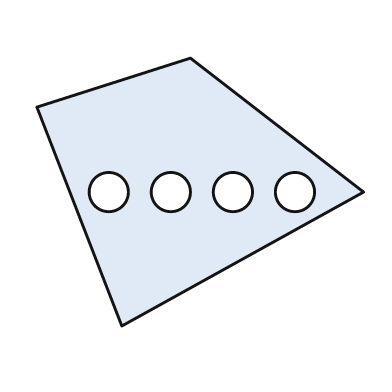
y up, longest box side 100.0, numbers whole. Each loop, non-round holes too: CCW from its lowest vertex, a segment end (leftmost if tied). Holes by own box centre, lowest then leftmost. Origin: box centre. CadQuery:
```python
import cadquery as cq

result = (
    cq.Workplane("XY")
    .moveTo(-24.0, -41.0)
    .lineTo(50.0, 0.0)
    .lineTo(-3.0, 41.0)
    .lineTo(-50.0, 26.0)
    .close()
    .moveTo(-28.0, 0.0)
    .circle(6.0)
    .moveTo(-9.0, 0.0)
    .circle(6.0)
    .moveTo(10.0, 0.0)
    .circle(6.0)
    .moveTo(29.0, 0.0)
    .circle(6.0)
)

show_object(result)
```